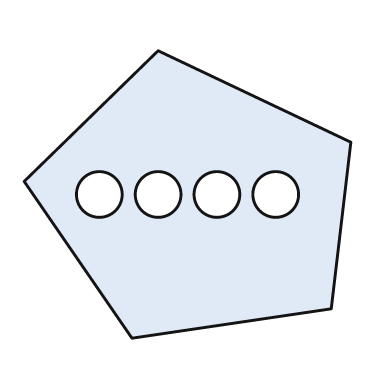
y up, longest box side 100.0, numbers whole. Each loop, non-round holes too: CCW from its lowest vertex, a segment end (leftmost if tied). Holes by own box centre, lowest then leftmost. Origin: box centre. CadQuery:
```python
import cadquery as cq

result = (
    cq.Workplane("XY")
    .moveTo(-17.0, -44.0)
    .lineTo(44.0, -35.0)
    .lineTo(50.0, 16.0)
    .lineTo(-9.0, 44.0)
    .lineTo(-50.0, 4.0)
    .close()
    .moveTo(-27.0, 0.0)
    .circle(7.0)
    .moveTo(-9.0, 0.0)
    .circle(7.0)
    .moveTo(9.0, 0.0)
    .circle(7.0)
    .moveTo(27.0, 0.0)
    .circle(7.0)
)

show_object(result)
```